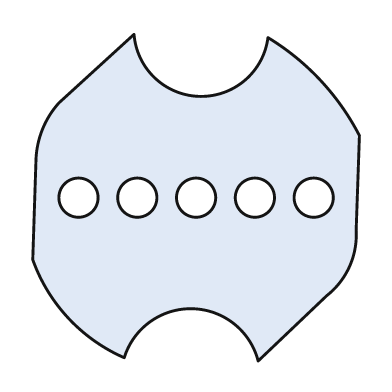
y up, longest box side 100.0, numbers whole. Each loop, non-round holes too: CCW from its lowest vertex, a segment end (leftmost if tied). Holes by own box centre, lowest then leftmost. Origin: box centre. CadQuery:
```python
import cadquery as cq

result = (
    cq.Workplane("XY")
    .moveTo(19.0, -50.0)
    .lineTo(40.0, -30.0)
    .threePointArc((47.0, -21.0), (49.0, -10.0))
    .lineTo(50.0, 19.0)
    .threePointArc((38.0, 36.0), (22.0, 49.0))
    .threePointArc((1.0, 31.0), (-19.0, 50.0))
    .lineTo(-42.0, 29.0)
    .threePointArc((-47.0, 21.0), (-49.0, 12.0))
    .lineTo(-50.0, -19.0)
    .threePointArc((-39.0, -37.0), (-22.0, -49.0))
    .threePointArc((-1.0, -34.0), (19.0, -50.0))
    .close()
    .moveTo(-36.0, 0.0)
    .circle(6.0)
    .moveTo(-18.0, 0.0)
    .circle(6.0)
    .moveTo(0.0, 0.0)
    .circle(6.0)
    .moveTo(18.0, 0.0)
    .circle(6.0)
    .moveTo(36.0, 0.0)
    .circle(6.0)
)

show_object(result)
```